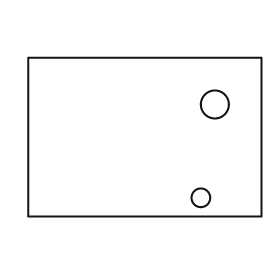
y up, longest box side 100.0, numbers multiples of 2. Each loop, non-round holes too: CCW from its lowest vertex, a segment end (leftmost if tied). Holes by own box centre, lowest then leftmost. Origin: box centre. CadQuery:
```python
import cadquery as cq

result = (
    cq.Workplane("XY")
    .moveTo(-50.0, -34.0)
    .lineTo(50.0, -34.0)
    .lineTo(50.0, 34.0)
    .lineTo(-50.0, 34.0)
    .close()
    .moveTo(24.0, -26.0)
    .circle(4.0)
    .moveTo(30.0, 14.0)
    .circle(6.0)
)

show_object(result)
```